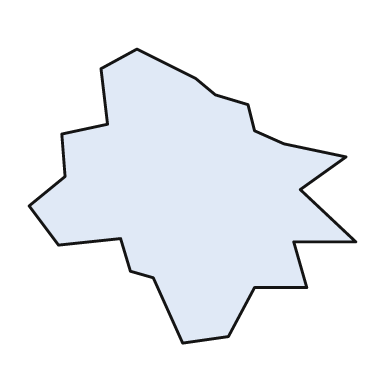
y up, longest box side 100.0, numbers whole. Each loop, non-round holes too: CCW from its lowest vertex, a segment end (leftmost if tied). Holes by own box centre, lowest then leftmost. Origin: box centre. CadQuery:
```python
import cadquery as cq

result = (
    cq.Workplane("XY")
    .moveTo(-3.0, -45.0)
    .lineTo(11.0, -43.0)
    .lineTo(19.0, -28.0)
    .lineTo(35.0, -28.0)
    .lineTo(31.0, -14.0)
    .lineTo(50.0, -14.0)
    .lineTo(33.0, 2.0)
    .lineTo(47.0, 12.0)
    .lineTo(28.0, 16.0)
    .lineTo(19.0, 20.0)
    .lineTo(17.0, 28.0)
    .lineTo(7.0, 31.0)
    .lineTo(1.0, 36.0)
    .lineTo(-17.0, 45.0)
    .lineTo(-28.0, 39.0)
    .lineTo(-26.0, 22.0)
    .lineTo(-40.0, 19.0)
    .lineTo(-39.0, 6.0)
    .lineTo(-50.0, -3.0)
    .lineTo(-41.0, -15.0)
    .lineTo(-22.0, -13.0)
    .lineTo(-19.0, -23.0)
    .lineTo(-12.0, -25.0)
    .close()
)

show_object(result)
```